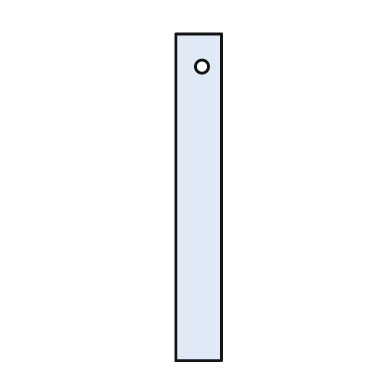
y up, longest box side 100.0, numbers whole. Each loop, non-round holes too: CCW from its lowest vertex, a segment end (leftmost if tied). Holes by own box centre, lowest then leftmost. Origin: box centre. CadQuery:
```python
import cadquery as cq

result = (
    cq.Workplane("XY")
    .moveTo(-7.0, -50.0)
    .lineTo(7.0, -50.0)
    .lineTo(7.0, 50.0)
    .lineTo(-7.0, 50.0)
    .close()
    .moveTo(1.0, 40.0)
    .circle(2.0)
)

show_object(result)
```